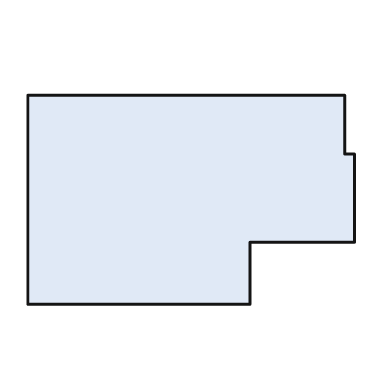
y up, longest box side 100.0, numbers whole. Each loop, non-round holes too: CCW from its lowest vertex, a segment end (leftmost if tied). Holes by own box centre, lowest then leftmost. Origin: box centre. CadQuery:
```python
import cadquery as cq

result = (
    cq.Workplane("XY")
    .moveTo(-50.0, -32.0)
    .lineTo(18.0, -32.0)
    .lineTo(18.0, -13.0)
    .lineTo(50.0, -13.0)
    .lineTo(50.0, 14.0)
    .lineTo(47.0, 14.0)
    .lineTo(47.0, 32.0)
    .lineTo(-50.0, 32.0)
    .close()
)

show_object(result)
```